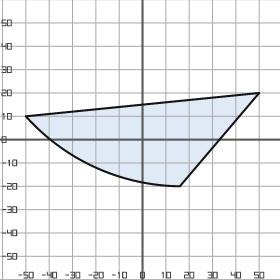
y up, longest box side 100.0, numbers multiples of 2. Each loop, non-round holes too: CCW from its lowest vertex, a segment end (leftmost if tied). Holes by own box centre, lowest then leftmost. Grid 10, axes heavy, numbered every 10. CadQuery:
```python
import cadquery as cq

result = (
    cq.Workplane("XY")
    .moveTo(16.0, -20.0)
    .lineTo(50.0, 20.0)
    .lineTo(-50.0, 10.0)
    .threePointArc((-20.0, -12.0), (16.0, -20.0))
    .close()
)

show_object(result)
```